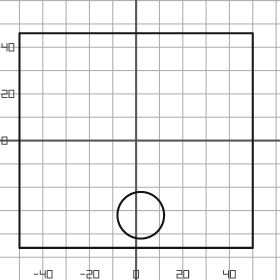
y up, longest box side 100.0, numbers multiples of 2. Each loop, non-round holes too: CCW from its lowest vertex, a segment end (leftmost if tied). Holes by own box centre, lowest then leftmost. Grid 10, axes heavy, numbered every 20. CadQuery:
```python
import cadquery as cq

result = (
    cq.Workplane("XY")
    .moveTo(-50.0, -46.0)
    .lineTo(50.0, -46.0)
    .lineTo(50.0, 46.0)
    .lineTo(-50.0, 46.0)
    .close()
    .moveTo(2.0, -32.0)
    .circle(10.0)
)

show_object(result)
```